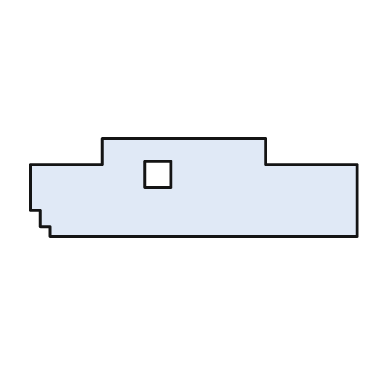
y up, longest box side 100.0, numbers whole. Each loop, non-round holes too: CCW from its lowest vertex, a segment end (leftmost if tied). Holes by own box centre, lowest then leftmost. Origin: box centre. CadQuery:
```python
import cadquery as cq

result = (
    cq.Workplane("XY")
    .moveTo(-44.0, -15.0)
    .lineTo(50.0, -15.0)
    .lineTo(50.0, 7.0)
    .lineTo(22.0, 7.0)
    .lineTo(22.0, 15.0)
    .lineTo(-28.0, 15.0)
    .lineTo(-28.0, 7.0)
    .lineTo(-50.0, 7.0)
    .lineTo(-50.0, -7.0)
    .lineTo(-47.0, -7.0)
    .lineTo(-47.0, -12.0)
    .lineTo(-44.0, -12.0)
    .close()
    .moveTo(-15.0, 0.0)
    .lineTo(-7.0, 0.0)
    .lineTo(-7.0, 8.0)
    .lineTo(-15.0, 8.0)
    .close()
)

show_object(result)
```